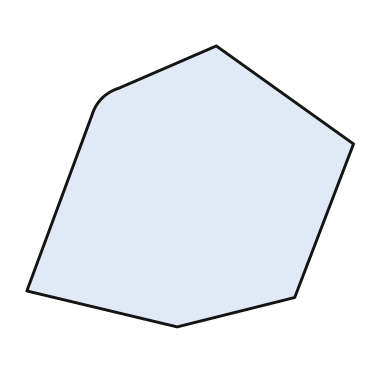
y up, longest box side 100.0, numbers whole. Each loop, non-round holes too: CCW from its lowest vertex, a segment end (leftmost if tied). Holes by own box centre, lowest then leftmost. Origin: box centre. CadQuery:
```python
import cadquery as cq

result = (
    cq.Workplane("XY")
    .moveTo(-4.0, -43.0)
    .lineTo(32.0, -34.0)
    .lineTo(50.0, 13.0)
    .lineTo(8.0, 43.0)
    .lineTo(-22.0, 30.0)
    .threePointArc((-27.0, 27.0), (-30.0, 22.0))
    .lineTo(-50.0, -32.0)
    .close()
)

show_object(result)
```